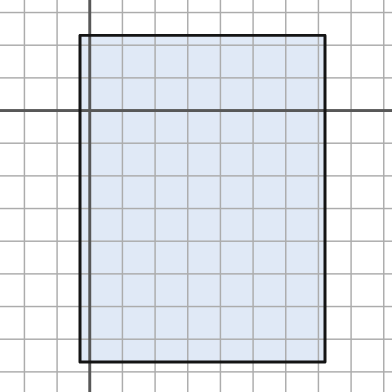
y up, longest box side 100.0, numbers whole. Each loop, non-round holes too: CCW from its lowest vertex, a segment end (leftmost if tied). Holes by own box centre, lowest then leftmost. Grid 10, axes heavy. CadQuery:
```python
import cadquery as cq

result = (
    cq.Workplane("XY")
    .moveTo(-3.0, -77.0)
    .lineTo(72.0, -77.0)
    .lineTo(72.0, 23.0)
    .lineTo(-3.0, 23.0)
    .close()
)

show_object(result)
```